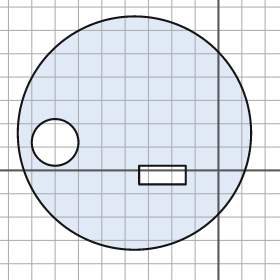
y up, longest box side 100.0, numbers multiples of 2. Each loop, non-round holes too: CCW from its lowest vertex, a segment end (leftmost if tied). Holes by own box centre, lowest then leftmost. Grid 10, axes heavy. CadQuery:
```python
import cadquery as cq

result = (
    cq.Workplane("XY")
    .moveTo(-36.0, 16.0)
    .circle(50.0)
    .moveTo(-34.0, -6.0)
    .lineTo(-14.0, -6.0)
    .lineTo(-14.0, 2.0)
    .lineTo(-34.0, 2.0)
    .close()
    .moveTo(-70.0, 12.0)
    .circle(10.0)
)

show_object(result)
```